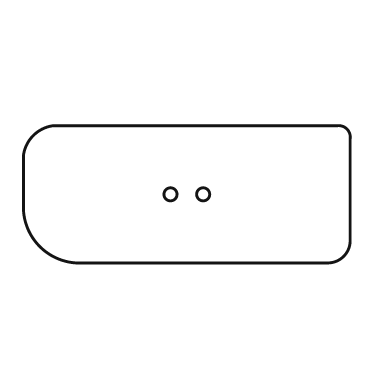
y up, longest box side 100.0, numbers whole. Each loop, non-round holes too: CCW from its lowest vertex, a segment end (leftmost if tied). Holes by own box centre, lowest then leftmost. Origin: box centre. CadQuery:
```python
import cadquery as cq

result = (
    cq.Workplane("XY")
    .moveTo(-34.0, -21.0)
    .lineTo(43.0, -21.0)
    .threePointArc((48.0, -19.0), (50.0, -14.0))
    .lineTo(50.0, 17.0)
    .threePointArc((49.0, 20.0), (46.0, 21.0))
    .lineTo(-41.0, 21.0)
    .threePointArc((-47.0, 18.0), (-50.0, 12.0))
    .lineTo(-50.0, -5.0)
    .threePointArc((-45.0, -16.0), (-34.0, -21.0))
    .close()
    .moveTo(-5.0, 0.0)
    .circle(2.0)
    .moveTo(5.0, 0.0)
    .circle(2.0)
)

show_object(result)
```